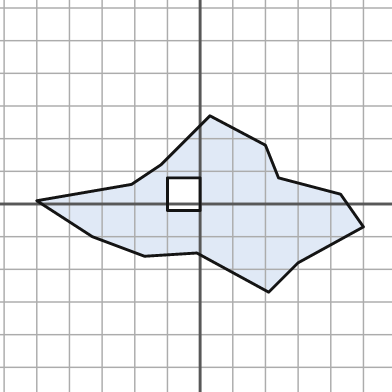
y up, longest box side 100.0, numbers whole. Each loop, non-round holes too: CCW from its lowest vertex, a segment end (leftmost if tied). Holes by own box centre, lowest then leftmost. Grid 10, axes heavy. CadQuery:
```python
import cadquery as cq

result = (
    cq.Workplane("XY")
    .moveTo(21.0, -27.0)
    .lineTo(30.0, -18.0)
    .lineTo(50.0, -7.0)
    .lineTo(43.0, 3.0)
    .lineTo(24.0, 8.0)
    .lineTo(20.0, 18.0)
    .lineTo(3.0, 27.0)
    .lineTo(-12.0, 12.0)
    .lineTo(-21.0, 6.0)
    .lineTo(-50.0, 1.0)
    .lineTo(-33.0, -10.0)
    .lineTo(-17.0, -16.0)
    .lineTo(-1.0, -15.0)
    .close()
    .moveTo(-10.0, -2.0)
    .lineTo(0.0, -2.0)
    .lineTo(0.0, 8.0)
    .lineTo(-10.0, 8.0)
    .close()
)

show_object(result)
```